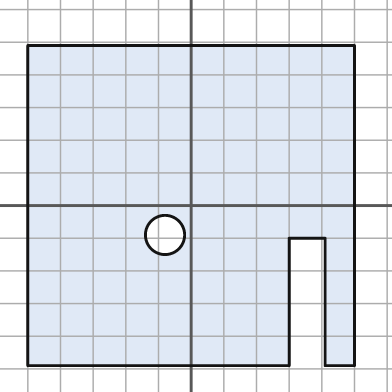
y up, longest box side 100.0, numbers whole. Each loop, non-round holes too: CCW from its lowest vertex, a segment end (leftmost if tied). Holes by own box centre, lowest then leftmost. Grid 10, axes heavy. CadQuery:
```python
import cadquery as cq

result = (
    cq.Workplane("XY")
    .moveTo(-50.0, -49.0)
    .lineTo(30.0, -49.0)
    .lineTo(30.0, -10.0)
    .lineTo(41.0, -10.0)
    .lineTo(41.0, -49.0)
    .lineTo(50.0, -49.0)
    .lineTo(50.0, 49.0)
    .lineTo(-50.0, 49.0)
    .close()
    .moveTo(-8.0, -9.0)
    .circle(6.0)
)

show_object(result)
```